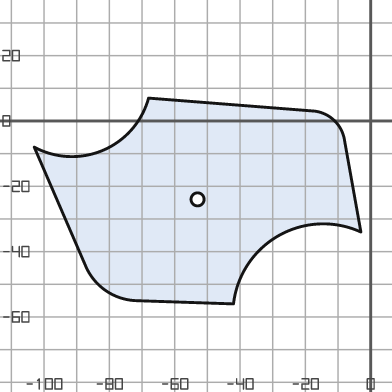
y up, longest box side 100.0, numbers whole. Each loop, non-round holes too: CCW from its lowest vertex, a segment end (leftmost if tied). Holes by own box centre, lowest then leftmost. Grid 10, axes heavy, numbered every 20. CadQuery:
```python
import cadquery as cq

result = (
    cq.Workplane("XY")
    .moveTo(-42.0, -56.0)
    .threePointArc((-28.0, -35.0), (-3.0, -34.0))
    .lineTo(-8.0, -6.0)
    .threePointArc((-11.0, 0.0), (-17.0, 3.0))
    .lineTo(-68.0, 7.0)
    .threePointArc((-82.0, -9.0), (-103.0, -8.0))
    .lineTo(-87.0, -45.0)
    .threePointArc((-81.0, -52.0), (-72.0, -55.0))
    .close()
    .moveTo(-53.0, -24.0)
    .circle(2.0)
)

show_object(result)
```